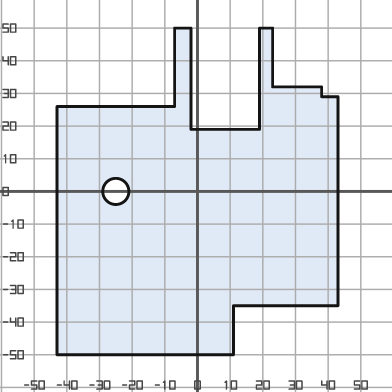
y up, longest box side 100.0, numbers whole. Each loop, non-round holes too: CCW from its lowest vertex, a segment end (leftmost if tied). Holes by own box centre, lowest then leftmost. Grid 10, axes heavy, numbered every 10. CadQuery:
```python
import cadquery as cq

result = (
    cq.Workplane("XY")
    .moveTo(-43.0, -50.0)
    .lineTo(11.0, -50.0)
    .lineTo(11.0, -35.0)
    .lineTo(43.0, -35.0)
    .lineTo(43.0, 29.0)
    .lineTo(38.0, 29.0)
    .lineTo(38.0, 32.0)
    .lineTo(23.0, 32.0)
    .lineTo(23.0, 50.0)
    .lineTo(19.0, 50.0)
    .lineTo(19.0, 19.0)
    .lineTo(-2.0, 19.0)
    .lineTo(-2.0, 50.0)
    .lineTo(-7.0, 50.0)
    .lineTo(-7.0, 26.0)
    .lineTo(-43.0, 26.0)
    .close()
    .moveTo(-25.0, 0.0)
    .circle(4.0)
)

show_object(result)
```